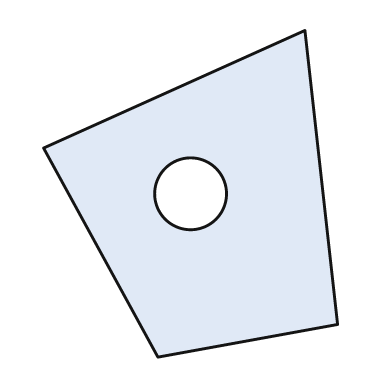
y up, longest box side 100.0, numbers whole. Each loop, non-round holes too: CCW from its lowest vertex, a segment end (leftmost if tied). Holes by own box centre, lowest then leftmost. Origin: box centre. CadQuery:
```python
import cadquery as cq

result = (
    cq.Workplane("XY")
    .moveTo(-10.0, -50.0)
    .lineTo(45.0, -40.0)
    .lineTo(35.0, 50.0)
    .lineTo(-45.0, 14.0)
    .close()
    .moveTo(0.0, 0.0)
    .circle(11.0)
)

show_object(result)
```